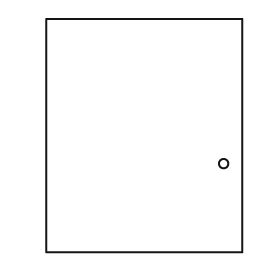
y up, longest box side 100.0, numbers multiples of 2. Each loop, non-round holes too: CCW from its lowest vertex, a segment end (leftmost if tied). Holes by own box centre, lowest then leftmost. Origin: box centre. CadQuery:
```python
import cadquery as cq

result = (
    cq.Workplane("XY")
    .moveTo(-42.0, -50.0)
    .lineTo(42.0, -50.0)
    .lineTo(42.0, 50.0)
    .lineTo(-42.0, 50.0)
    .close()
    .moveTo(34.0, -12.0)
    .circle(2.0)
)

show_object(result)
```